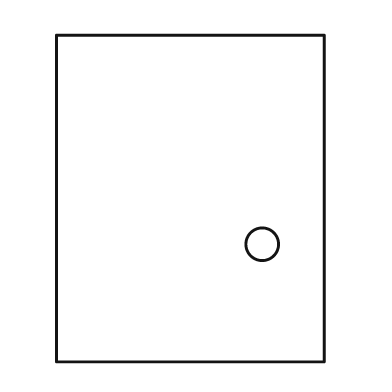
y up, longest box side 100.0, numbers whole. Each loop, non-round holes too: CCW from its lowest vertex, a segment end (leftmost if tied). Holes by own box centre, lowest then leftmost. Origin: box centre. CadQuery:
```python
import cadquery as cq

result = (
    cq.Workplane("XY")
    .moveTo(-41.0, -50.0)
    .lineTo(41.0, -50.0)
    .lineTo(41.0, 50.0)
    .lineTo(-41.0, 50.0)
    .close()
    .moveTo(22.0, -14.0)
    .circle(5.0)
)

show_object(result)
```